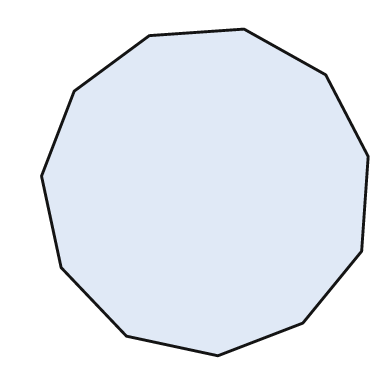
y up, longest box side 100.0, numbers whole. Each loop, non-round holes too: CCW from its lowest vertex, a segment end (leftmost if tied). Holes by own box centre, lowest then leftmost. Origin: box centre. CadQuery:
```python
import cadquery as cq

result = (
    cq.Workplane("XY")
    .moveTo(4.0, -50.0)
    .lineTo(30.0, -40.0)
    .lineTo(48.0, -18.0)
    .lineTo(50.0, 11.0)
    .lineTo(37.0, 36.0)
    .lineTo(12.0, 50.0)
    .lineTo(-17.0, 48.0)
    .lineTo(-40.0, 31.0)
    .lineTo(-50.0, 5.0)
    .lineTo(-44.0, -23.0)
    .lineTo(-24.0, -44.0)
    .close()
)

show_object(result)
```